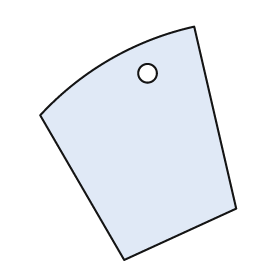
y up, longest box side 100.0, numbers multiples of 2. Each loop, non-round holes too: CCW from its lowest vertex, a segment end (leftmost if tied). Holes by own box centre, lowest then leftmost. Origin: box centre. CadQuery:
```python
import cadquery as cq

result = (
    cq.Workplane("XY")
    .moveTo(-6.0, -50.0)
    .lineTo(42.0, -28.0)
    .lineTo(24.0, 50.0)
    .threePointArc((-12.0, 36.0), (-42.0, 12.0))
    .close()
    .moveTo(4.0, 30.0)
    .circle(4.0)
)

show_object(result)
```